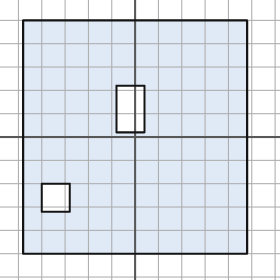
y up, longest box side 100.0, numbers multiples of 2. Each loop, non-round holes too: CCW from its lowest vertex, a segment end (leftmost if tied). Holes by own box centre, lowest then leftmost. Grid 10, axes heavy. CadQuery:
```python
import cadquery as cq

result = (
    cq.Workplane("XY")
    .moveTo(-48.0, -50.0)
    .lineTo(48.0, -50.0)
    .lineTo(48.0, 50.0)
    .lineTo(-48.0, 50.0)
    .close()
    .moveTo(-40.0, -32.0)
    .lineTo(-28.0, -32.0)
    .lineTo(-28.0, -20.0)
    .lineTo(-40.0, -20.0)
    .close()
    .moveTo(-8.0, 2.0)
    .lineTo(4.0, 2.0)
    .lineTo(4.0, 22.0)
    .lineTo(-8.0, 22.0)
    .close()
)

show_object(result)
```